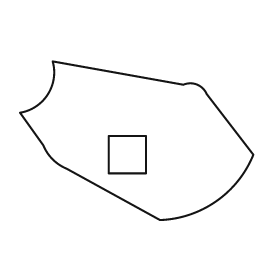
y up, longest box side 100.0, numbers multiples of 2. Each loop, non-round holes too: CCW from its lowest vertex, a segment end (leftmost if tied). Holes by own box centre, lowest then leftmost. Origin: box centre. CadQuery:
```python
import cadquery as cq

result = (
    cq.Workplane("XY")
    .moveTo(10.0, -34.0)
    .threePointArc((34.0, -26.0), (50.0, -6.0))
    .lineTo(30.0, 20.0)
    .threePointArc((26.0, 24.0), (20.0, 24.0))
    .lineTo(-36.0, 34.0)
    .threePointArc((-38.0, 20.0), (-50.0, 12.0))
    .lineTo(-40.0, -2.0)
    .threePointArc((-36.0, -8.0), (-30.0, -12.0))
    .close()
    .moveTo(-12.0, -14.0)
    .lineTo(4.0, -14.0)
    .lineTo(4.0, 2.0)
    .lineTo(-12.0, 2.0)
    .close()
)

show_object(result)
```